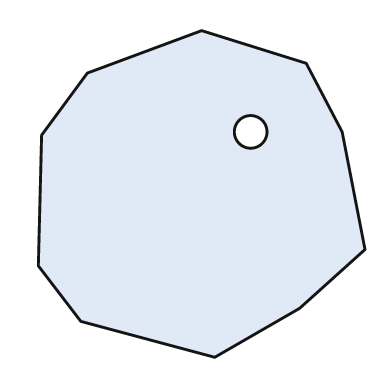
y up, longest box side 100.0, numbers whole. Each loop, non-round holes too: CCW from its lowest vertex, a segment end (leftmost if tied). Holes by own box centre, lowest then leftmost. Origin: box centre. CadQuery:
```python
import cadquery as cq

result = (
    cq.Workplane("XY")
    .moveTo(4.0, -50.0)
    .lineTo(30.0, -35.0)
    .lineTo(50.0, -17.0)
    .lineTo(43.0, 19.0)
    .lineTo(32.0, 40.0)
    .lineTo(0.0, 50.0)
    .lineTo(-35.0, 37.0)
    .lineTo(-49.0, 18.0)
    .lineTo(-50.0, -22.0)
    .lineTo(-37.0, -39.0)
    .close()
    .moveTo(15.0, 19.0)
    .circle(5.0)
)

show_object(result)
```